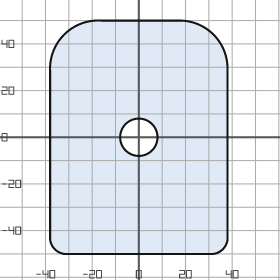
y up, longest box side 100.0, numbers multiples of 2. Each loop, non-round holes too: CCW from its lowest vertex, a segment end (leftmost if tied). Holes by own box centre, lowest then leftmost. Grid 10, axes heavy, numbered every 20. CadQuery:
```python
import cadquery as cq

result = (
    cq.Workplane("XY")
    .moveTo(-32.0, -50.0)
    .lineTo(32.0, -50.0)
    .threePointArc((36.0, -48.0), (38.0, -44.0))
    .lineTo(38.0, 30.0)
    .threePointArc((32.0, 44.0), (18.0, 50.0))
    .lineTo(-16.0, 50.0)
    .threePointArc((-32.0, 44.0), (-38.0, 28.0))
    .lineTo(-38.0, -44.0)
    .threePointArc((-36.0, -48.0), (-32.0, -50.0))
    .close()
    .moveTo(0.0, 0.0)
    .circle(8.0)
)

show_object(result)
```